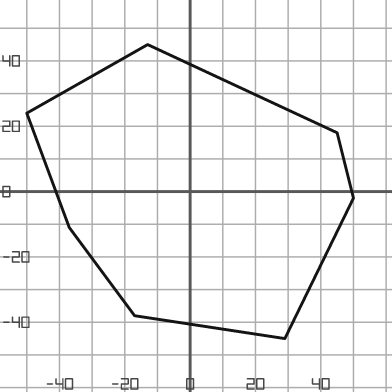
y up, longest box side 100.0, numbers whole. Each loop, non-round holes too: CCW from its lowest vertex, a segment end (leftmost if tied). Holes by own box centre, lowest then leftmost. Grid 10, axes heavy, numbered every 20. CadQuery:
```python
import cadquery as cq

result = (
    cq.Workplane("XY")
    .moveTo(29.0, -45.0)
    .lineTo(50.0, -2.0)
    .lineTo(45.0, 18.0)
    .lineTo(-13.0, 45.0)
    .lineTo(-50.0, 24.0)
    .lineTo(-37.0, -11.0)
    .lineTo(-17.0, -38.0)
    .close()
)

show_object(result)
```